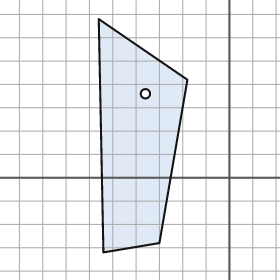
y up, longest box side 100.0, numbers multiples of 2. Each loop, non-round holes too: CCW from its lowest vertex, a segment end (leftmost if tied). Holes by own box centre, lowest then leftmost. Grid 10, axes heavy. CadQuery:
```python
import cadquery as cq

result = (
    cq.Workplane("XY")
    .moveTo(-54.0, -32.0)
    .lineTo(-30.0, -28.0)
    .lineTo(-18.0, 42.0)
    .lineTo(-56.0, 68.0)
    .close()
    .moveTo(-36.0, 36.0)
    .circle(2.0)
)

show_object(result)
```